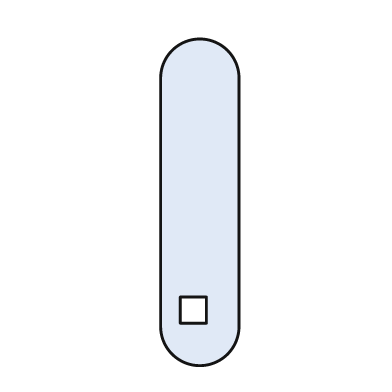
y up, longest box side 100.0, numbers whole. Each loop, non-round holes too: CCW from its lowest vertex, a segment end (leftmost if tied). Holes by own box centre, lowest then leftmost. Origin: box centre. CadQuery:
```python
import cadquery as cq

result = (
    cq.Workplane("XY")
    .moveTo(-12.0, -38.0)
    .threePointArc((0.0, -50.0), (12.0, -38.0))
    .lineTo(12.0, 38.0)
    .threePointArc((0.0, 50.0), (-12.0, 38.0))
    .close()
    .moveTo(-6.0, -37.0)
    .lineTo(2.0, -37.0)
    .lineTo(2.0, -29.0)
    .lineTo(-6.0, -29.0)
    .close()
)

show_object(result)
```